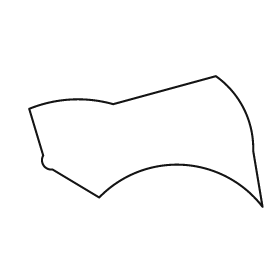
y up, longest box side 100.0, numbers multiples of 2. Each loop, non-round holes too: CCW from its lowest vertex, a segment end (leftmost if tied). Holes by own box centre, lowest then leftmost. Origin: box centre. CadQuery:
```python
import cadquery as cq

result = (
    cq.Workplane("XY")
    .moveTo(50.0, -28.0)
    .lineTo(46.0, -4.0)
    .threePointArc((42.0, 14.0), (30.0, 28.0))
    .lineTo(-14.0, 16.0)
    .threePointArc((-32.0, 18.0), (-50.0, 14.0))
    .lineTo(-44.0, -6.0)
    .threePointArc((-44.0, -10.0), (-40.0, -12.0))
    .lineTo(-20.0, -24.0)
    .threePointArc((16.0, -10.0), (50.0, -28.0))
    .close()
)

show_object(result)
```